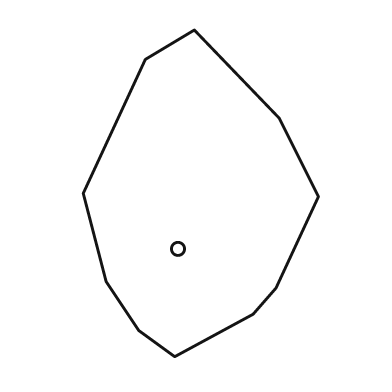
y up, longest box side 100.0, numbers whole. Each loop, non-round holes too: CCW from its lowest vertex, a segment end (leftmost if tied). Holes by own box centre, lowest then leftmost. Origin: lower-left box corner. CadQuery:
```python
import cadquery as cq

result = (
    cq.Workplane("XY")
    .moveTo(28.0, 0.0)
    .lineTo(52.0, 13.0)
    .lineTo(59.0, 21.0)
    .lineTo(72.0, 49.0)
    .lineTo(60.0, 73.0)
    .lineTo(34.0, 100.0)
    .lineTo(19.0, 91.0)
    .lineTo(0.0, 50.0)
    .lineTo(7.0, 23.0)
    .lineTo(17.0, 8.0)
    .close()
    .moveTo(29.0, 33.0)
    .circle(2.0)
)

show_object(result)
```